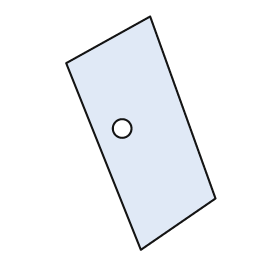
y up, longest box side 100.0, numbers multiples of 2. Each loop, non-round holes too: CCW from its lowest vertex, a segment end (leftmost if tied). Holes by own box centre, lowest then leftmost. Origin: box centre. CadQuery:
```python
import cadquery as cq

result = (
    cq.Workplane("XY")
    .moveTo(0.0, -50.0)
    .lineTo(32.0, -28.0)
    .lineTo(4.0, 50.0)
    .lineTo(-32.0, 30.0)
    .close()
    .moveTo(-8.0, 2.0)
    .circle(4.0)
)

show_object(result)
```